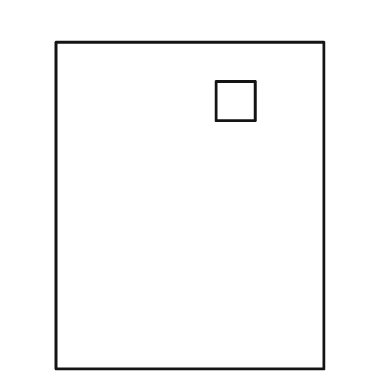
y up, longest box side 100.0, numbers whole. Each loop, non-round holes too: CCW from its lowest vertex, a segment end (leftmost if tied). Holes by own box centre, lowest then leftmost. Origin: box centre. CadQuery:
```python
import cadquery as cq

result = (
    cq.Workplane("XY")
    .moveTo(-41.0, -50.0)
    .lineTo(41.0, -50.0)
    .lineTo(41.0, 50.0)
    .lineTo(-41.0, 50.0)
    .close()
    .moveTo(8.0, 26.0)
    .lineTo(20.0, 26.0)
    .lineTo(20.0, 38.0)
    .lineTo(8.0, 38.0)
    .close()
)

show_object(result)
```